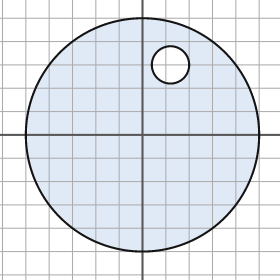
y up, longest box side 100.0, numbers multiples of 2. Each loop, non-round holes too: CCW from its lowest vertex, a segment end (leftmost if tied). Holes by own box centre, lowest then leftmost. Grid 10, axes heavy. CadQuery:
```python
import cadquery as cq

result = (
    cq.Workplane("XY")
    .moveTo(0.0, 0.0)
    .circle(50.0)
    .moveTo(12.0, 30.0)
    .circle(8.0)
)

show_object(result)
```